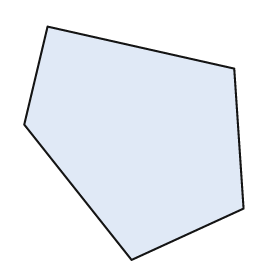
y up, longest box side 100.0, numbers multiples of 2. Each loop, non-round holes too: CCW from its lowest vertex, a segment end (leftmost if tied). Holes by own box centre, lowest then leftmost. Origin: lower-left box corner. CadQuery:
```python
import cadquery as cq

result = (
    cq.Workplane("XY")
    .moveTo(46.0, 0.0)
    .lineTo(94.0, 22.0)
    .lineTo(90.0, 82.0)
    .lineTo(10.0, 100.0)
    .lineTo(0.0, 58.0)
    .close()
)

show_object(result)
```